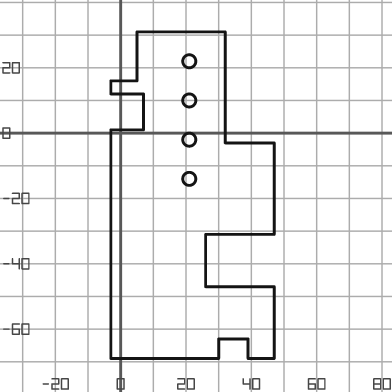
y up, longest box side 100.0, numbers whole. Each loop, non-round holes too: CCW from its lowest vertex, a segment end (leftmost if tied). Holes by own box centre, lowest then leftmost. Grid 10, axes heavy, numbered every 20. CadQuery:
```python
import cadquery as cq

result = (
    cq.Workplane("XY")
    .moveTo(-3.0, -69.0)
    .lineTo(30.0, -69.0)
    .lineTo(30.0, -63.0)
    .lineTo(39.0, -63.0)
    .lineTo(39.0, -69.0)
    .lineTo(47.0, -69.0)
    .lineTo(47.0, -47.0)
    .lineTo(26.0, -47.0)
    .lineTo(26.0, -31.0)
    .lineTo(47.0, -31.0)
    .lineTo(47.0, -3.0)
    .lineTo(32.0, -3.0)
    .lineTo(32.0, 31.0)
    .lineTo(5.0, 31.0)
    .lineTo(5.0, 16.0)
    .lineTo(-3.0, 16.0)
    .lineTo(-3.0, 12.0)
    .lineTo(7.0, 12.0)
    .lineTo(7.0, 1.0)
    .lineTo(-3.0, 1.0)
    .close()
    .moveTo(21.0, -14.0)
    .circle(2.0)
    .moveTo(21.0, -2.0)
    .circle(2.0)
    .moveTo(21.0, 10.0)
    .circle(2.0)
    .moveTo(21.0, 22.0)
    .circle(2.0)
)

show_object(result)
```